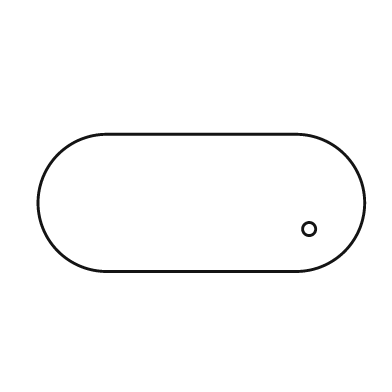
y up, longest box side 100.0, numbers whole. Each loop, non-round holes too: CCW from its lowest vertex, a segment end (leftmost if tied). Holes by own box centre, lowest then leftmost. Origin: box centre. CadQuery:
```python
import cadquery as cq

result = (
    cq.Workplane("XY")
    .moveTo(-29.0, -21.0)
    .lineTo(29.0, -21.0)
    .threePointArc((50.0, 0.0), (29.0, 21.0))
    .lineTo(-29.0, 21.0)
    .threePointArc((-50.0, 0.0), (-29.0, -21.0))
    .close()
    .moveTo(33.0, -8.0)
    .circle(2.0)
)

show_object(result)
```